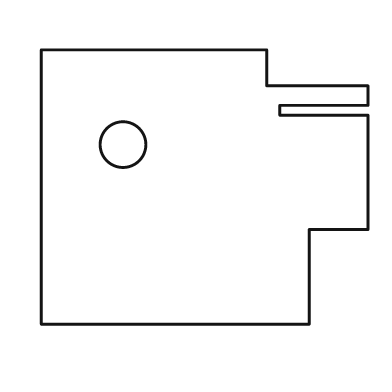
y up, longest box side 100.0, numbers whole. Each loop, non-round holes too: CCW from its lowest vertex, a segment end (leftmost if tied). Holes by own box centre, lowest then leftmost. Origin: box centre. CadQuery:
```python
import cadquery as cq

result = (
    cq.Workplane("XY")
    .moveTo(-50.0, -42.0)
    .lineTo(32.0, -42.0)
    .lineTo(32.0, -13.0)
    .lineTo(50.0, -13.0)
    .lineTo(50.0, 22.0)
    .lineTo(23.0, 22.0)
    .lineTo(23.0, 25.0)
    .lineTo(50.0, 25.0)
    .lineTo(50.0, 31.0)
    .lineTo(19.0, 31.0)
    .lineTo(19.0, 42.0)
    .lineTo(-50.0, 42.0)
    .close()
    .moveTo(-25.0, 13.0)
    .circle(7.0)
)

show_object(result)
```